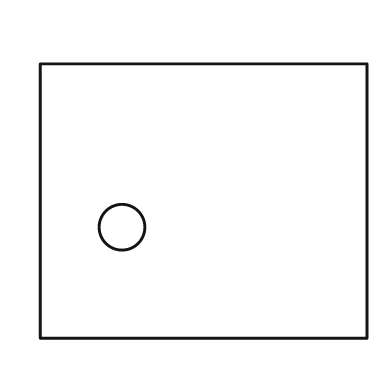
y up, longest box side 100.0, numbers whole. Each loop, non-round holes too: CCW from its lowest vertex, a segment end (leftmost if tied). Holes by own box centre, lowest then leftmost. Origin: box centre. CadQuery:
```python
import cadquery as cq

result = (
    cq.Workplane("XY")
    .moveTo(-50.0, -42.0)
    .lineTo(50.0, -42.0)
    .lineTo(50.0, 42.0)
    .lineTo(-50.0, 42.0)
    .close()
    .moveTo(-25.0, -8.0)
    .circle(7.0)
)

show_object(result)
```